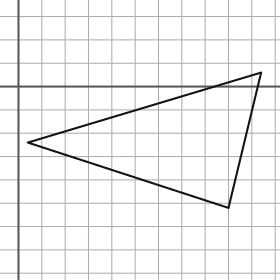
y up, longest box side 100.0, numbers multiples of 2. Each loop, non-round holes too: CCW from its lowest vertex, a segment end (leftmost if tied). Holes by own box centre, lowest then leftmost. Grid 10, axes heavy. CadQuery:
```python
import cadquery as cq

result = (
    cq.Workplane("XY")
    .moveTo(90.0, -52.0)
    .lineTo(104.0, 6.0)
    .lineTo(4.0, -24.0)
    .close()
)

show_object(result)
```